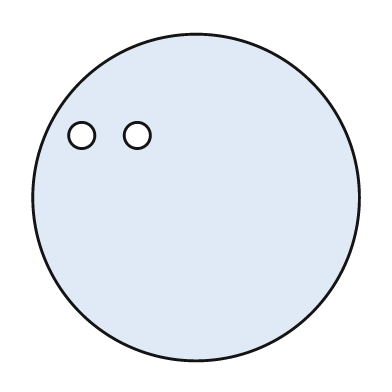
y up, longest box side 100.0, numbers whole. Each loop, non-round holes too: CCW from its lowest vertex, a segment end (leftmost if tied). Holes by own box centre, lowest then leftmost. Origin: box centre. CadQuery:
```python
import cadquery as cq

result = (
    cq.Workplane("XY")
    .moveTo(0.0, 0.0)
    .circle(50.0)
    .moveTo(-35.0, 19.0)
    .circle(4.0)
    .moveTo(-18.0, 19.0)
    .circle(4.0)
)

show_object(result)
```